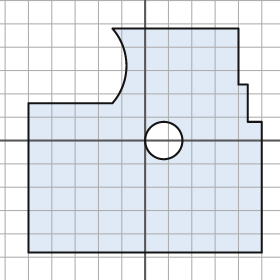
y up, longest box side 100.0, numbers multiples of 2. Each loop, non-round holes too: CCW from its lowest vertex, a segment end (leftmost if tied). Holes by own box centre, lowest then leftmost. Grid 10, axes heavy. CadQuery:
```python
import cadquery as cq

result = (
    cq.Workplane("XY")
    .moveTo(-50.0, -48.0)
    .lineTo(50.0, -48.0)
    .lineTo(50.0, 8.0)
    .lineTo(44.0, 8.0)
    .lineTo(44.0, 24.0)
    .lineTo(40.0, 24.0)
    .lineTo(40.0, 48.0)
    .lineTo(-14.0, 48.0)
    .threePointArc((-8.0, 32.0), (-14.0, 16.0))
    .lineTo(-50.0, 16.0)
    .close()
    .moveTo(8.0, 0.0)
    .circle(8.0)
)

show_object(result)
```